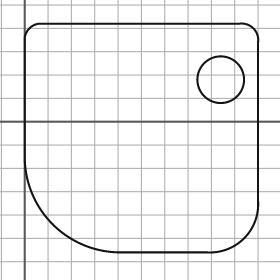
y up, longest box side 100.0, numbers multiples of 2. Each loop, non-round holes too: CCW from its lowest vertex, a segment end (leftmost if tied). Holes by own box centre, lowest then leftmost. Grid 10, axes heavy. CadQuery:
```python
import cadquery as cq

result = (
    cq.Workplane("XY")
    .moveTo(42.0, -56.0)
    .lineTo(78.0, -56.0)
    .threePointArc((94.0, -50.0), (100.0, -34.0))
    .lineTo(100.0, 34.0)
    .threePointArc((98.0, 40.0), (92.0, 42.0))
    .lineTo(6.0, 42.0)
    .threePointArc((2.0, 40.0), (0.0, 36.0))
    .lineTo(0.0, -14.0)
    .threePointArc((12.0, -44.0), (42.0, -56.0))
    .close()
    .moveTo(84.0, 18.0)
    .circle(10.0)
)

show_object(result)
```